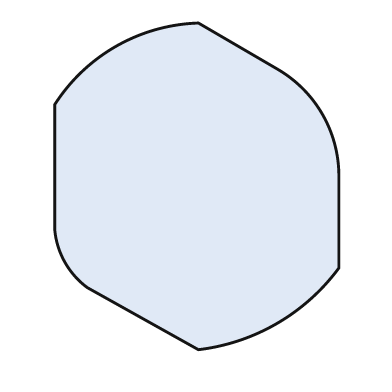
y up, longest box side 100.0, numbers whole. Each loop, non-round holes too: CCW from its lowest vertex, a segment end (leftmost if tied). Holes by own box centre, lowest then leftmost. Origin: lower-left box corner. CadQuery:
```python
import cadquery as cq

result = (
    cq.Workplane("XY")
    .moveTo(44.0, 0.0)
    .threePointArc((68.0, 8.0), (87.0, 25.0))
    .lineTo(87.0, 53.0)
    .threePointArc((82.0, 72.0), (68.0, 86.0))
    .lineTo(44.0, 100.0)
    .threePointArc((19.0, 93.0), (0.0, 75.0))
    .lineTo(0.0, 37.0)
    .threePointArc((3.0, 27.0), (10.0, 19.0))
    .close()
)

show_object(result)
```